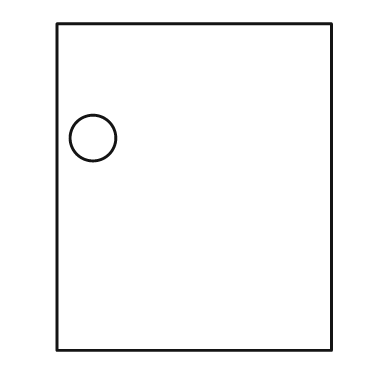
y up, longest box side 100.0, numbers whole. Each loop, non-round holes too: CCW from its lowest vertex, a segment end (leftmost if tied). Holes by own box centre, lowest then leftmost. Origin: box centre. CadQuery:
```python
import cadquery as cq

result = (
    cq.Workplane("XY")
    .moveTo(-42.0, -50.0)
    .lineTo(42.0, -50.0)
    .lineTo(42.0, 50.0)
    .lineTo(-42.0, 50.0)
    .close()
    .moveTo(-31.0, 15.0)
    .circle(7.0)
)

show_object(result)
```